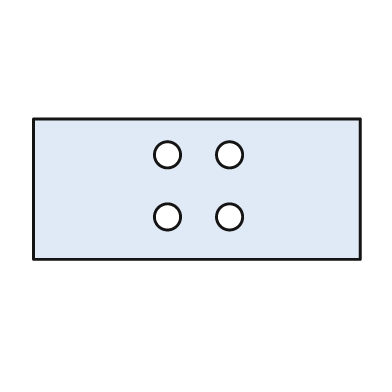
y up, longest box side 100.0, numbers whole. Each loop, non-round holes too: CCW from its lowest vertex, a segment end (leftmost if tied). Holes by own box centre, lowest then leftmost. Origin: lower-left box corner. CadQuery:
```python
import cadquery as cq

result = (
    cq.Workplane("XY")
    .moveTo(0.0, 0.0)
    .lineTo(100.0, 0.0)
    .lineTo(100.0, 43.0)
    .lineTo(0.0, 43.0)
    .close()
    .moveTo(41.0, 13.0)
    .circle(4.0)
    .moveTo(60.0, 13.0)
    .circle(4.0)
    .moveTo(41.0, 32.0)
    .circle(4.0)
    .moveTo(60.0, 32.0)
    .circle(4.0)
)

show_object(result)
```